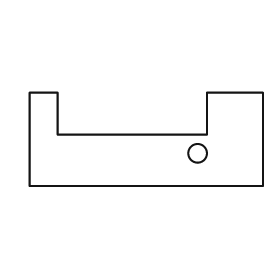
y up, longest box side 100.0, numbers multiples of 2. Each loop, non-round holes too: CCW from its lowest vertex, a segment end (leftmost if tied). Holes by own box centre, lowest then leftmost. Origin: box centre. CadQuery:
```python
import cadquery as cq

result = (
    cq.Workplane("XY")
    .moveTo(-50.0, -20.0)
    .lineTo(50.0, -20.0)
    .lineTo(50.0, 20.0)
    .lineTo(26.0, 20.0)
    .lineTo(26.0, 2.0)
    .lineTo(-38.0, 2.0)
    .lineTo(-38.0, 20.0)
    .lineTo(-50.0, 20.0)
    .close()
    .moveTo(22.0, -6.0)
    .circle(4.0)
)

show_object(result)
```